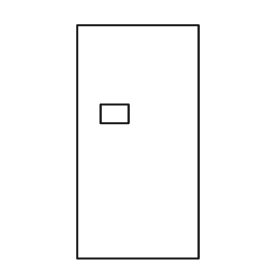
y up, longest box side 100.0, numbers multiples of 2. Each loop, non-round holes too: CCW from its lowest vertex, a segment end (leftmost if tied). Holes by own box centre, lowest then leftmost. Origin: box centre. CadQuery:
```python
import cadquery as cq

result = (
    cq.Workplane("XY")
    .moveTo(-26.0, -50.0)
    .lineTo(26.0, -50.0)
    .lineTo(26.0, 50.0)
    .lineTo(-26.0, 50.0)
    .close()
    .moveTo(-16.0, 8.0)
    .lineTo(-4.0, 8.0)
    .lineTo(-4.0, 16.0)
    .lineTo(-16.0, 16.0)
    .close()
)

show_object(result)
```